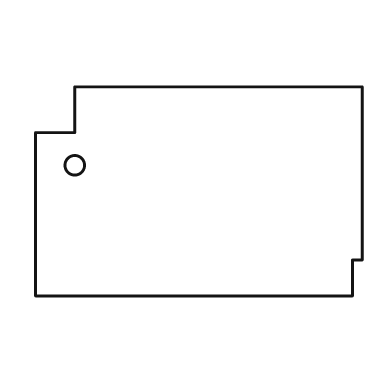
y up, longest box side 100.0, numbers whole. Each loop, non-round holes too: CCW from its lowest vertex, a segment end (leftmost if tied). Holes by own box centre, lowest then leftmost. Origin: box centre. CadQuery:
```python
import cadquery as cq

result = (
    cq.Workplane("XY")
    .moveTo(-50.0, -32.0)
    .lineTo(47.0, -32.0)
    .lineTo(47.0, -21.0)
    .lineTo(50.0, -21.0)
    .lineTo(50.0, 32.0)
    .lineTo(-38.0, 32.0)
    .lineTo(-38.0, 18.0)
    .lineTo(-50.0, 18.0)
    .close()
    .moveTo(-38.0, 8.0)
    .circle(3.0)
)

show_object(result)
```